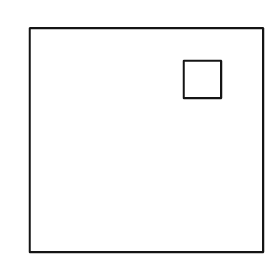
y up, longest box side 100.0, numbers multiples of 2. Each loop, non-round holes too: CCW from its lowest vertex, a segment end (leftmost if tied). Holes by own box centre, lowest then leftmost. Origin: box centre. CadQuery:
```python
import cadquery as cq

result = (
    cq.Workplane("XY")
    .moveTo(-50.0, -48.0)
    .lineTo(50.0, -48.0)
    .lineTo(50.0, 48.0)
    .lineTo(-50.0, 48.0)
    .close()
    .moveTo(16.0, 18.0)
    .lineTo(32.0, 18.0)
    .lineTo(32.0, 34.0)
    .lineTo(16.0, 34.0)
    .close()
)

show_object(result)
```